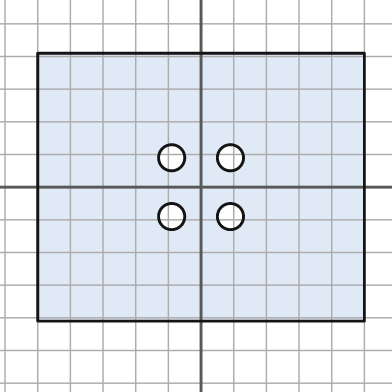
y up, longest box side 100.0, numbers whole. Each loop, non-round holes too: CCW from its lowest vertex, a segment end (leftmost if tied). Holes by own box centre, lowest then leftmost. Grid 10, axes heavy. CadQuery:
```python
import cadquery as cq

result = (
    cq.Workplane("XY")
    .moveTo(-50.0, -41.0)
    .lineTo(50.0, -41.0)
    .lineTo(50.0, 41.0)
    .lineTo(-50.0, 41.0)
    .close()
    .moveTo(-9.0, -9.0)
    .circle(4.0)
    .moveTo(9.0, -9.0)
    .circle(4.0)
    .moveTo(-9.0, 9.0)
    .circle(4.0)
    .moveTo(9.0, 9.0)
    .circle(4.0)
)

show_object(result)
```